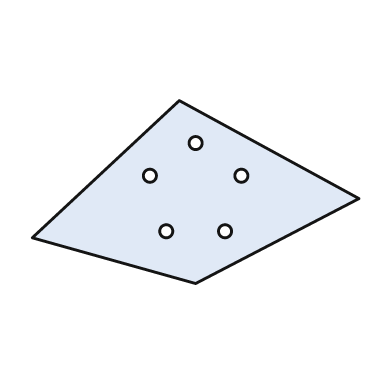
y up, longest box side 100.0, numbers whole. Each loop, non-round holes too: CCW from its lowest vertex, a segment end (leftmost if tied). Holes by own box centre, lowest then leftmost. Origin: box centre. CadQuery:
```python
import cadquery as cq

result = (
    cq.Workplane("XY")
    .moveTo(0.0, -28.0)
    .lineTo(50.0, -2.0)
    .lineTo(-5.0, 28.0)
    .lineTo(-50.0, -14.0)
    .close()
    .moveTo(-9.0, -12.0)
    .circle(2.0)
    .moveTo(9.0, -12.0)
    .circle(2.0)
    .moveTo(-14.0, 5.0)
    .circle(2.0)
    .moveTo(14.0, 5.0)
    .circle(2.0)
    .moveTo(0.0, 15.0)
    .circle(2.0)
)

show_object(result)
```